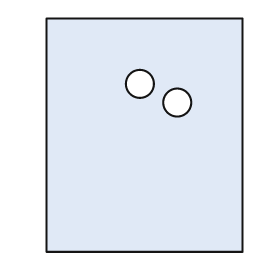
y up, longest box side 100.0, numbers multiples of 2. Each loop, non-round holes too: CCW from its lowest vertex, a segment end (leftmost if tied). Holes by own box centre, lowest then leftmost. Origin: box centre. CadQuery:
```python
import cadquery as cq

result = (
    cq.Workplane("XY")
    .moveTo(-42.0, -50.0)
    .lineTo(42.0, -50.0)
    .lineTo(42.0, 50.0)
    .lineTo(-42.0, 50.0)
    .close()
    .moveTo(14.0, 14.0)
    .circle(6.0)
    .moveTo(-2.0, 22.0)
    .circle(6.0)
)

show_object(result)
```